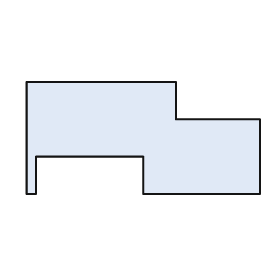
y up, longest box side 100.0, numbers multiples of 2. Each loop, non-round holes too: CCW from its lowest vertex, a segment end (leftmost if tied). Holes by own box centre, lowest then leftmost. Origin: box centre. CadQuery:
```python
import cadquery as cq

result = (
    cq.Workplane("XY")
    .moveTo(-50.0, -24.0)
    .lineTo(-46.0, -24.0)
    .lineTo(-46.0, -8.0)
    .lineTo(0.0, -8.0)
    .lineTo(0.0, -24.0)
    .lineTo(50.0, -24.0)
    .lineTo(50.0, 8.0)
    .lineTo(14.0, 8.0)
    .lineTo(14.0, 24.0)
    .lineTo(-50.0, 24.0)
    .close()
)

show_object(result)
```